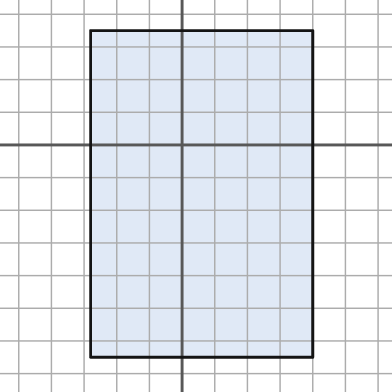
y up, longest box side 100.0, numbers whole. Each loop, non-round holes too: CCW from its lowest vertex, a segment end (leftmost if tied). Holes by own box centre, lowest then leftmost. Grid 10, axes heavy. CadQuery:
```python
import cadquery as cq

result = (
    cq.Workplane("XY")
    .moveTo(-28.0, -65.0)
    .lineTo(40.0, -65.0)
    .lineTo(40.0, 35.0)
    .lineTo(-28.0, 35.0)
    .close()
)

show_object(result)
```